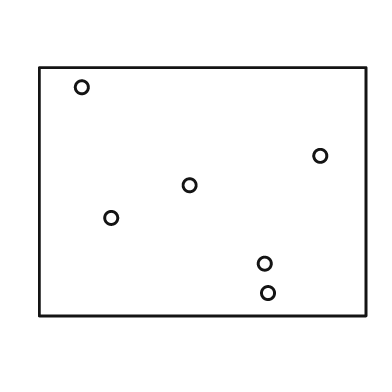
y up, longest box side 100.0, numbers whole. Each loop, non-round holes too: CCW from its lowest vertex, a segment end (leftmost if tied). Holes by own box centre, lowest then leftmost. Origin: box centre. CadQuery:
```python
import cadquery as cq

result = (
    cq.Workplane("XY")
    .moveTo(-50.0, -38.0)
    .lineTo(50.0, -38.0)
    .lineTo(50.0, 38.0)
    .lineTo(-50.0, 38.0)
    .close()
    .moveTo(20.0, -31.0)
    .circle(2.0)
    .moveTo(19.0, -22.0)
    .circle(2.0)
    .moveTo(-28.0, -8.0)
    .circle(2.0)
    .moveTo(-4.0, 2.0)
    .circle(2.0)
    .moveTo(36.0, 11.0)
    .circle(2.0)
    .moveTo(-37.0, 32.0)
    .circle(2.0)
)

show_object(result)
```